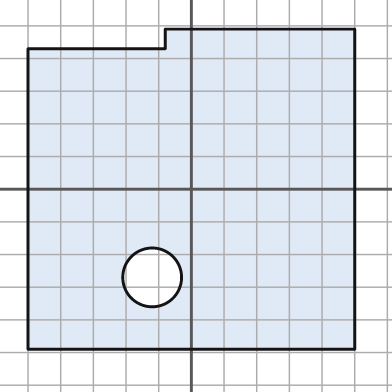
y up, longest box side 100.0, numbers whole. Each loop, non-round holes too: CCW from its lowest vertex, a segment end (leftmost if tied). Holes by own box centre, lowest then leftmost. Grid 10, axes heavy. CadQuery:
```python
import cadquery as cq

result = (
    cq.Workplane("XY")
    .moveTo(-50.0, -49.0)
    .lineTo(50.0, -49.0)
    .lineTo(50.0, 49.0)
    .lineTo(-8.0, 49.0)
    .lineTo(-8.0, 43.0)
    .lineTo(-50.0, 43.0)
    .close()
    .moveTo(-12.0, -27.0)
    .circle(9.0)
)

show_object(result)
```